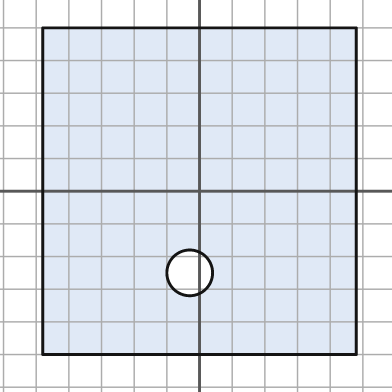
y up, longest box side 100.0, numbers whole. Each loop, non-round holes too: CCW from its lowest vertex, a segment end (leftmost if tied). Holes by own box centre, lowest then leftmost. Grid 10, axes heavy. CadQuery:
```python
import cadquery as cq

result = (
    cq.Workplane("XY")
    .moveTo(-48.0, -50.0)
    .lineTo(48.0, -50.0)
    .lineTo(48.0, 50.0)
    .lineTo(-48.0, 50.0)
    .close()
    .moveTo(-3.0, -25.0)
    .circle(7.0)
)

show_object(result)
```